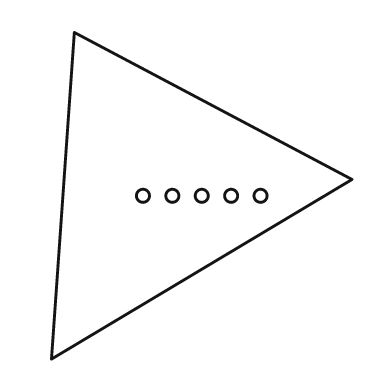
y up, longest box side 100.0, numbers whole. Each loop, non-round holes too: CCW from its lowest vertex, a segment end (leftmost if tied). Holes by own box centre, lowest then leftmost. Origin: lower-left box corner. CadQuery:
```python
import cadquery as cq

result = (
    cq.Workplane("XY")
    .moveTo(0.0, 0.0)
    .lineTo(92.0, 55.0)
    .lineTo(7.0, 100.0)
    .close()
    .moveTo(28.0, 50.0)
    .circle(2.0)
    .moveTo(37.0, 50.0)
    .circle(2.0)
    .moveTo(46.0, 50.0)
    .circle(2.0)
    .moveTo(55.0, 50.0)
    .circle(2.0)
    .moveTo(64.0, 50.0)
    .circle(2.0)
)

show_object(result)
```